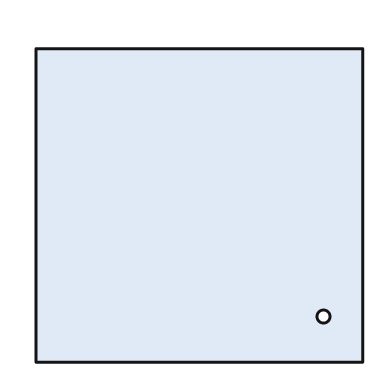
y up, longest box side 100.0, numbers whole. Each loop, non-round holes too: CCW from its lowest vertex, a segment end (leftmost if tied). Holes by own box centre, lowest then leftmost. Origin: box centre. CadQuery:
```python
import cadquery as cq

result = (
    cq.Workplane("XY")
    .moveTo(-50.0, -48.0)
    .lineTo(50.0, -48.0)
    .lineTo(50.0, 48.0)
    .lineTo(-50.0, 48.0)
    .close()
    .moveTo(38.0, -34.0)
    .circle(2.0)
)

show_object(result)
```